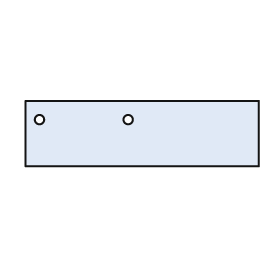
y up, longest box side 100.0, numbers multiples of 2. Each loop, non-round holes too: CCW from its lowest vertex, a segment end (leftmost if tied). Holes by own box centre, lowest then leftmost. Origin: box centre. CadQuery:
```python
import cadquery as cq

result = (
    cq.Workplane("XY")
    .moveTo(-50.0, -14.0)
    .lineTo(50.0, -14.0)
    .lineTo(50.0, 14.0)
    .lineTo(-50.0, 14.0)
    .close()
    .moveTo(-44.0, 6.0)
    .circle(2.0)
    .moveTo(-6.0, 6.0)
    .circle(2.0)
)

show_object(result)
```